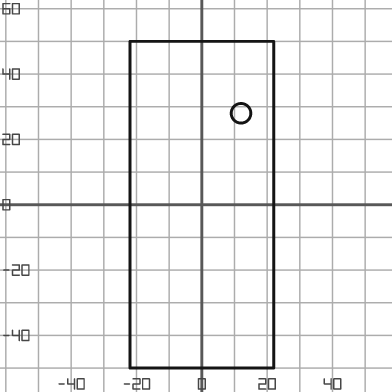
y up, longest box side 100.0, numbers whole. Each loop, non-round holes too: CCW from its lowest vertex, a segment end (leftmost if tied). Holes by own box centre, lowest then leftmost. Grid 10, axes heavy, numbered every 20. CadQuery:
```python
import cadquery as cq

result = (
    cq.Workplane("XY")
    .moveTo(-22.0, -50.0)
    .lineTo(22.0, -50.0)
    .lineTo(22.0, 50.0)
    .lineTo(-22.0, 50.0)
    .close()
    .moveTo(12.0, 28.0)
    .circle(3.0)
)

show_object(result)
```